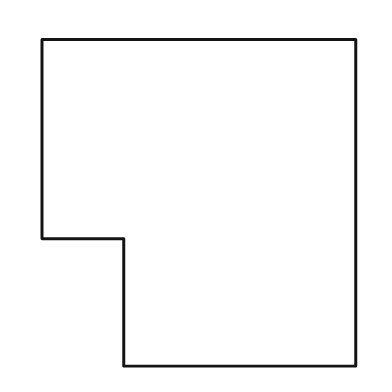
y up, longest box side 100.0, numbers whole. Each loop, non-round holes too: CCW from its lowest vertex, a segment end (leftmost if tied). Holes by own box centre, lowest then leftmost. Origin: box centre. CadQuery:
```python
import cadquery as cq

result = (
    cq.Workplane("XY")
    .moveTo(-23.0, -50.0)
    .lineTo(48.0, -50.0)
    .lineTo(48.0, 50.0)
    .lineTo(-48.0, 50.0)
    .lineTo(-48.0, -11.0)
    .lineTo(-23.0, -11.0)
    .close()
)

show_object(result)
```